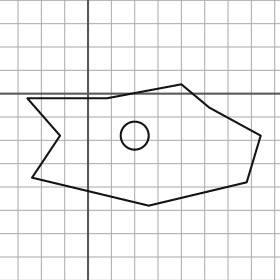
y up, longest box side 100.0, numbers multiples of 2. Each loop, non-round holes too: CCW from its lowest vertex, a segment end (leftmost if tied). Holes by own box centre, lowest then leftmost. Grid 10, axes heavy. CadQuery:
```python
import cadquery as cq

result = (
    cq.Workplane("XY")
    .moveTo(26.0, -48.0)
    .lineTo(68.0, -38.0)
    .lineTo(74.0, -18.0)
    .lineTo(52.0, -6.0)
    .lineTo(40.0, 4.0)
    .lineTo(8.0, -2.0)
    .lineTo(-26.0, -2.0)
    .lineTo(-12.0, -18.0)
    .lineTo(-24.0, -36.0)
    .close()
    .moveTo(20.0, -18.0)
    .circle(6.0)
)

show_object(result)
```